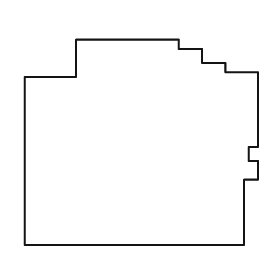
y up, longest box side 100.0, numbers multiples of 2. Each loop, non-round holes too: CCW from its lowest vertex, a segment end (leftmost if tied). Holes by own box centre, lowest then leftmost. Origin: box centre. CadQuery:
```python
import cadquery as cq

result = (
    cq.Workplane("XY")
    .moveTo(-50.0, -44.0)
    .lineTo(44.0, -44.0)
    .lineTo(44.0, -16.0)
    .lineTo(50.0, -16.0)
    .lineTo(50.0, -8.0)
    .lineTo(46.0, -8.0)
    .lineTo(46.0, -2.0)
    .lineTo(50.0, -2.0)
    .lineTo(50.0, 30.0)
    .lineTo(36.0, 30.0)
    .lineTo(36.0, 34.0)
    .lineTo(26.0, 34.0)
    .lineTo(26.0, 40.0)
    .lineTo(16.0, 40.0)
    .lineTo(16.0, 44.0)
    .lineTo(-28.0, 44.0)
    .lineTo(-28.0, 28.0)
    .lineTo(-50.0, 28.0)
    .close()
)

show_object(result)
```